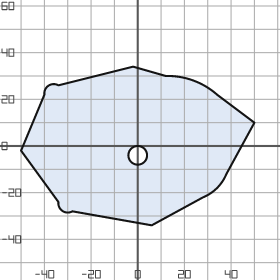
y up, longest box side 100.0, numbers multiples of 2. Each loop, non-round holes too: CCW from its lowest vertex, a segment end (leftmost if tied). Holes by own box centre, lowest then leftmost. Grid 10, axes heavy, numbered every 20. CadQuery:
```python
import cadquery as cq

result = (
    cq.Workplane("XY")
    .moveTo(6.0, -34.0)
    .lineTo(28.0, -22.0)
    .threePointArc((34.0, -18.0), (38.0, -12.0))
    .lineTo(50.0, 10.0)
    .lineTo(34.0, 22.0)
    .threePointArc((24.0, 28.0), (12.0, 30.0))
    .lineTo(-2.0, 34.0)
    .lineTo(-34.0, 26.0)
    .threePointArc((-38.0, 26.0), (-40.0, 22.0))
    .lineTo(-50.0, -2.0)
    .lineTo(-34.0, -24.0)
    .threePointArc((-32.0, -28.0), (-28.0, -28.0))
    .close()
    .moveTo(0.0, -4.0)
    .circle(4.0)
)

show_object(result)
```